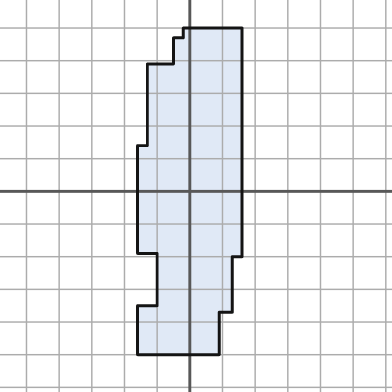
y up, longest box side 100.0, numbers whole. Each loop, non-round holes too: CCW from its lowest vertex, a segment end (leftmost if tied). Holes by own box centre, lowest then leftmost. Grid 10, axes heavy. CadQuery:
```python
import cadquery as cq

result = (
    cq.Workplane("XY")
    .moveTo(-16.0, -50.0)
    .lineTo(9.0, -50.0)
    .lineTo(9.0, -37.0)
    .lineTo(13.0, -37.0)
    .lineTo(13.0, -20.0)
    .lineTo(16.0, -20.0)
    .lineTo(16.0, 50.0)
    .lineTo(-2.0, 50.0)
    .lineTo(-2.0, 47.0)
    .lineTo(-5.0, 47.0)
    .lineTo(-5.0, 39.0)
    .lineTo(-13.0, 39.0)
    .lineTo(-13.0, 14.0)
    .lineTo(-16.0, 14.0)
    .lineTo(-16.0, -19.0)
    .lineTo(-10.0, -19.0)
    .lineTo(-10.0, -35.0)
    .lineTo(-16.0, -35.0)
    .close()
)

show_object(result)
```